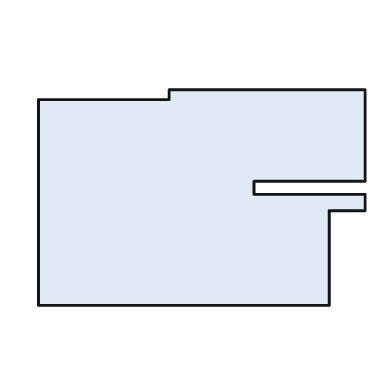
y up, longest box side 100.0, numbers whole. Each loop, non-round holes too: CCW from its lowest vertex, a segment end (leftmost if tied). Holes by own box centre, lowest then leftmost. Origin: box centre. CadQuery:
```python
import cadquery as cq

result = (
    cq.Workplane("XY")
    .moveTo(-50.0, -33.0)
    .lineTo(39.0, -33.0)
    .lineTo(39.0, -4.0)
    .lineTo(50.0, -4.0)
    .lineTo(50.0, 1.0)
    .lineTo(16.0, 1.0)
    .lineTo(16.0, 5.0)
    .lineTo(50.0, 5.0)
    .lineTo(50.0, 33.0)
    .lineTo(-10.0, 33.0)
    .lineTo(-10.0, 30.0)
    .lineTo(-50.0, 30.0)
    .close()
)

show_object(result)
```